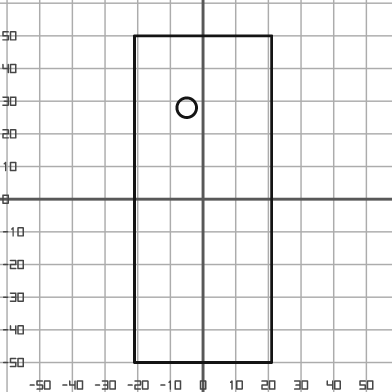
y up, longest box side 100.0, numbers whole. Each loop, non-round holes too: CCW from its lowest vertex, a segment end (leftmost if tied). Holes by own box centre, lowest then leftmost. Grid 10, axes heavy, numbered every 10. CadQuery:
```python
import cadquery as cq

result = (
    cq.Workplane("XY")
    .moveTo(-21.0, -50.0)
    .lineTo(21.0, -50.0)
    .lineTo(21.0, 50.0)
    .lineTo(-21.0, 50.0)
    .close()
    .moveTo(-5.0, 28.0)
    .circle(3.0)
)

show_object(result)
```